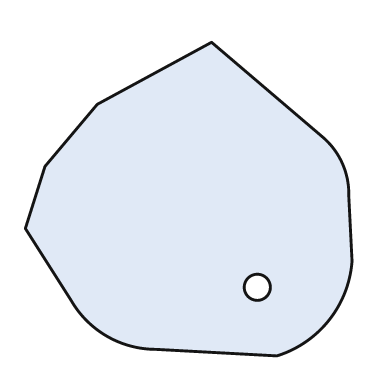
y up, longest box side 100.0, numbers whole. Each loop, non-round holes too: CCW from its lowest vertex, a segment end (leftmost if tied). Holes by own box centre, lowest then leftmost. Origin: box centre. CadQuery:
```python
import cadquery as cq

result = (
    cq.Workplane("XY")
    .moveTo(27.0, -48.0)
    .threePointArc((43.0, -37.0), (50.0, -19.0))
    .lineTo(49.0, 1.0)
    .threePointArc((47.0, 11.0), (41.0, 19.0))
    .lineTo(7.0, 48.0)
    .lineTo(-28.0, 29.0)
    .lineTo(-44.0, 10.0)
    .lineTo(-50.0, -9.0)
    .lineTo(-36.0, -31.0)
    .threePointArc((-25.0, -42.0), (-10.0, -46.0))
    .close()
    .moveTo(21.0, -27.0)
    .circle(4.0)
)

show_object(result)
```